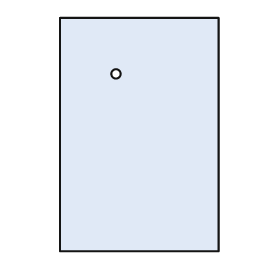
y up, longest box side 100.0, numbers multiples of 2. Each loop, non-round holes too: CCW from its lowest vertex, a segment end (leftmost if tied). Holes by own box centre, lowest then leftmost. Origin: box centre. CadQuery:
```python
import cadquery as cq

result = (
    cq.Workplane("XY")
    .moveTo(-34.0, -50.0)
    .lineTo(34.0, -50.0)
    .lineTo(34.0, 50.0)
    .lineTo(-34.0, 50.0)
    .close()
    .moveTo(-10.0, 26.0)
    .circle(2.0)
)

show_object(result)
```